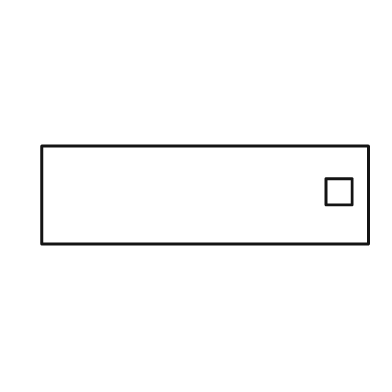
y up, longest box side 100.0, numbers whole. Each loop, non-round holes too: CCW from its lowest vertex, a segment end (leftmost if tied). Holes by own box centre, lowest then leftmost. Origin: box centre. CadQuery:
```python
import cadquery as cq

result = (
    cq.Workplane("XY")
    .moveTo(-50.0, -15.0)
    .lineTo(50.0, -15.0)
    .lineTo(50.0, 15.0)
    .lineTo(-50.0, 15.0)
    .close()
    .moveTo(37.0, -3.0)
    .lineTo(45.0, -3.0)
    .lineTo(45.0, 5.0)
    .lineTo(37.0, 5.0)
    .close()
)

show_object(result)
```